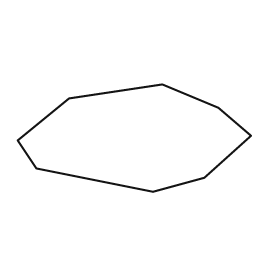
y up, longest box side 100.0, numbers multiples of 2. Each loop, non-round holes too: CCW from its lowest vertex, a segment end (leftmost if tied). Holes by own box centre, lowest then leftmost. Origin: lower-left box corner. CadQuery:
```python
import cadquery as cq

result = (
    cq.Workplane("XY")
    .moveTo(58.0, 0.0)
    .lineTo(80.0, 6.0)
    .lineTo(100.0, 24.0)
    .lineTo(86.0, 36.0)
    .lineTo(62.0, 46.0)
    .lineTo(22.0, 40.0)
    .lineTo(0.0, 22.0)
    .lineTo(8.0, 10.0)
    .close()
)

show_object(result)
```